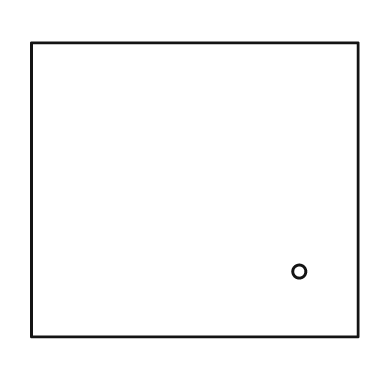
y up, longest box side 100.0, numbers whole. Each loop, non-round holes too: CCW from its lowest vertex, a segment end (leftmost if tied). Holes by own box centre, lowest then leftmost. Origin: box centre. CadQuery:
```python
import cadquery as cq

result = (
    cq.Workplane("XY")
    .moveTo(-50.0, -45.0)
    .lineTo(50.0, -45.0)
    .lineTo(50.0, 45.0)
    .lineTo(-50.0, 45.0)
    .close()
    .moveTo(32.0, -25.0)
    .circle(2.0)
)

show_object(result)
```